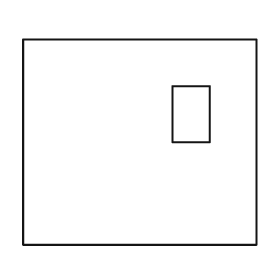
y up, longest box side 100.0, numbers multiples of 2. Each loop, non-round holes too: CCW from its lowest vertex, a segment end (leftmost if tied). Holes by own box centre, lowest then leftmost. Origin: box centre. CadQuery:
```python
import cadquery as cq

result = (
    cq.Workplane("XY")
    .moveTo(-50.0, -44.0)
    .lineTo(50.0, -44.0)
    .lineTo(50.0, 44.0)
    .lineTo(-50.0, 44.0)
    .close()
    .moveTo(14.0, 0.0)
    .lineTo(30.0, 0.0)
    .lineTo(30.0, 24.0)
    .lineTo(14.0, 24.0)
    .close()
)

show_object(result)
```